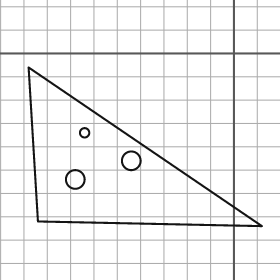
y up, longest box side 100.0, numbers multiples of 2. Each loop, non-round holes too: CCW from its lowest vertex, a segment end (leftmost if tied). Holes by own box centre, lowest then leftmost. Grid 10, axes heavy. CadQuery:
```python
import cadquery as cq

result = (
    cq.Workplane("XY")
    .moveTo(12.0, -74.0)
    .lineTo(-88.0, -6.0)
    .lineTo(-84.0, -72.0)
    .close()
    .moveTo(-68.0, -54.0)
    .circle(4.0)
    .moveTo(-44.0, -46.0)
    .circle(4.0)
    .moveTo(-64.0, -34.0)
    .circle(2.0)
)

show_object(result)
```